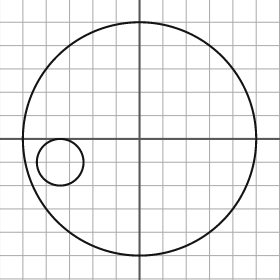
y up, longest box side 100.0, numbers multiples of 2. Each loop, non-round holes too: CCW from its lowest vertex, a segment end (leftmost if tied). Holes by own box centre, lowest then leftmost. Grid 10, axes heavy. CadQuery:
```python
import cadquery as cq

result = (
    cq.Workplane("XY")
    .moveTo(0.0, 0.0)
    .circle(50.0)
    .moveTo(-34.0, -10.0)
    .circle(10.0)
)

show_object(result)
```